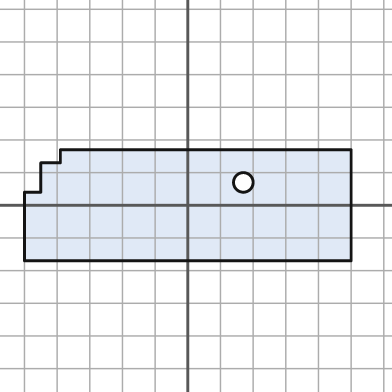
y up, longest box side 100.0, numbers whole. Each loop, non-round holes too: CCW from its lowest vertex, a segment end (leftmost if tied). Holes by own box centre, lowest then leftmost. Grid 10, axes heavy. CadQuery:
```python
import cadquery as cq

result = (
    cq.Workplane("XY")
    .moveTo(-50.0, -17.0)
    .lineTo(50.0, -17.0)
    .lineTo(50.0, 17.0)
    .lineTo(-39.0, 17.0)
    .lineTo(-39.0, 13.0)
    .lineTo(-45.0, 13.0)
    .lineTo(-45.0, 4.0)
    .lineTo(-50.0, 4.0)
    .close()
    .moveTo(17.0, 7.0)
    .circle(3.0)
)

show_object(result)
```